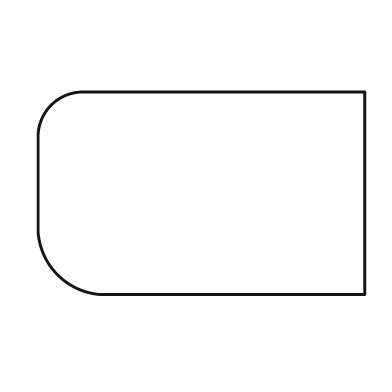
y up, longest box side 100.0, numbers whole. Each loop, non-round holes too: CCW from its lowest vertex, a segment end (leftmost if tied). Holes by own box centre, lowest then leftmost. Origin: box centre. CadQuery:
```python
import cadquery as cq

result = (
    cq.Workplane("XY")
    .moveTo(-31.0, -31.0)
    .lineTo(50.0, -31.0)
    .lineTo(50.0, 31.0)
    .lineTo(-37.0, 31.0)
    .threePointArc((-46.0, 27.0), (-50.0, 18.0))
    .lineTo(-50.0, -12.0)
    .threePointArc((-44.0, -25.0), (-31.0, -31.0))
    .close()
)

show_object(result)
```